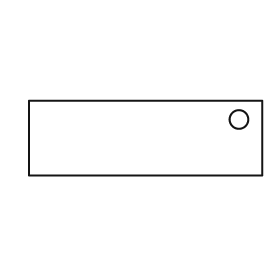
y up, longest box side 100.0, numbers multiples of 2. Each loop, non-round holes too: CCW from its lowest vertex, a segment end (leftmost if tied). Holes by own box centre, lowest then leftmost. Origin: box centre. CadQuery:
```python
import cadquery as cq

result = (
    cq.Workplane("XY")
    .moveTo(-50.0, -16.0)
    .lineTo(50.0, -16.0)
    .lineTo(50.0, 16.0)
    .lineTo(-50.0, 16.0)
    .close()
    .moveTo(40.0, 8.0)
    .circle(4.0)
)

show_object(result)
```